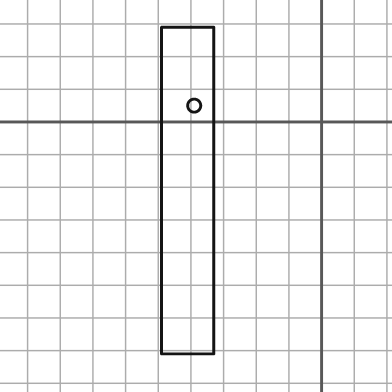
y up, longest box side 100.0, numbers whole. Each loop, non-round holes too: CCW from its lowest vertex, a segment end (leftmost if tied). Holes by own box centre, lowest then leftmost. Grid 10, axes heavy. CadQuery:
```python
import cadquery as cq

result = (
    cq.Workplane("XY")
    .moveTo(-49.0, -71.0)
    .lineTo(-33.0, -71.0)
    .lineTo(-33.0, 29.0)
    .lineTo(-49.0, 29.0)
    .close()
    .moveTo(-39.0, 5.0)
    .circle(2.0)
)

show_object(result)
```